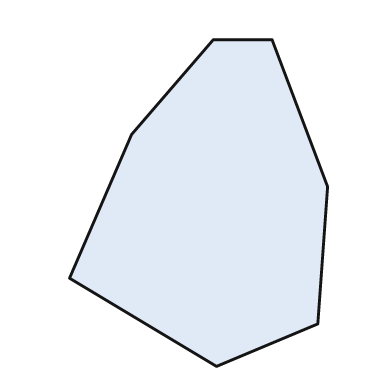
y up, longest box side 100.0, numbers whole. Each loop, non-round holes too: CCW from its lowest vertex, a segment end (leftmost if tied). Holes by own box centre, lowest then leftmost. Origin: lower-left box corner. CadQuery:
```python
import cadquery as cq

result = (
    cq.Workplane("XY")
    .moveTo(45.0, 0.0)
    .lineTo(76.0, 13.0)
    .lineTo(79.0, 55.0)
    .lineTo(62.0, 100.0)
    .lineTo(44.0, 100.0)
    .lineTo(19.0, 71.0)
    .lineTo(0.0, 27.0)
    .close()
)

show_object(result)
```